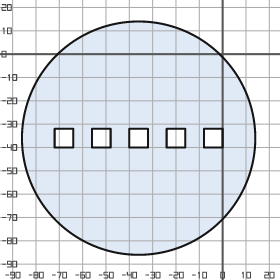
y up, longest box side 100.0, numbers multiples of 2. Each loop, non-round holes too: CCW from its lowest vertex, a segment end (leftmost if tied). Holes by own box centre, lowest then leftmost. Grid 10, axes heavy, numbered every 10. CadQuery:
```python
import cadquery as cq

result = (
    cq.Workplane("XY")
    .moveTo(-36.0, -36.0)
    .circle(50.0)
    .moveTo(-72.0, -40.0)
    .lineTo(-64.0, -40.0)
    .lineTo(-64.0, -32.0)
    .lineTo(-72.0, -32.0)
    .close()
    .moveTo(-56.0, -40.0)
    .lineTo(-48.0, -40.0)
    .lineTo(-48.0, -32.0)
    .lineTo(-56.0, -32.0)
    .close()
    .moveTo(-40.0, -40.0)
    .lineTo(-32.0, -40.0)
    .lineTo(-32.0, -32.0)
    .lineTo(-40.0, -32.0)
    .close()
    .moveTo(-24.0, -40.0)
    .lineTo(-16.0, -40.0)
    .lineTo(-16.0, -32.0)
    .lineTo(-24.0, -32.0)
    .close()
    .moveTo(-8.0, -40.0)
    .lineTo(0.0, -40.0)
    .lineTo(0.0, -32.0)
    .lineTo(-8.0, -32.0)
    .close()
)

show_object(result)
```